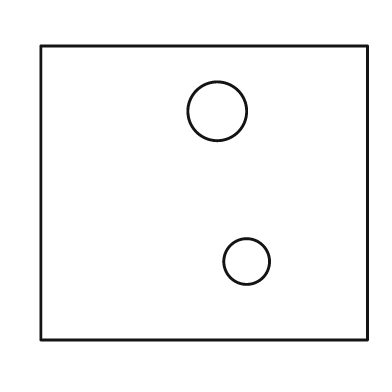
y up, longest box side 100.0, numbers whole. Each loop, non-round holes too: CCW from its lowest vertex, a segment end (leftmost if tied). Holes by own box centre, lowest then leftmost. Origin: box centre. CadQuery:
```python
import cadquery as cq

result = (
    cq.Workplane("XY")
    .moveTo(-50.0, -45.0)
    .lineTo(50.0, -45.0)
    .lineTo(50.0, 45.0)
    .lineTo(-50.0, 45.0)
    .close()
    .moveTo(13.0, -21.0)
    .circle(7.0)
    .moveTo(4.0, 25.0)
    .circle(9.0)
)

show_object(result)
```